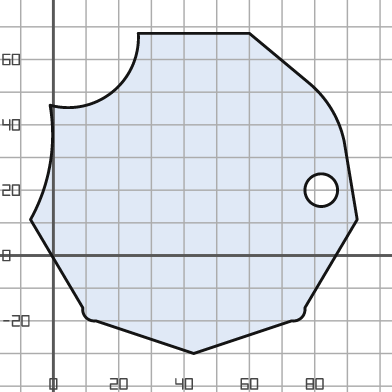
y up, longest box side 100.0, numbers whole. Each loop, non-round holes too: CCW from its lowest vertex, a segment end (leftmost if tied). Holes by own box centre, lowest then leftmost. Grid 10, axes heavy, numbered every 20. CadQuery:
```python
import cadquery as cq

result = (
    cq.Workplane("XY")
    .moveTo(43.0, -30.0)
    .lineTo(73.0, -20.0)
    .threePointArc((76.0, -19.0), (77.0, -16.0))
    .lineTo(93.0, 11.0)
    .lineTo(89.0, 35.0)
    .threePointArc((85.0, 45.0), (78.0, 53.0))
    .lineTo(60.0, 68.0)
    .lineTo(26.0, 68.0)
    .threePointArc((18.0, 50.0), (-1.0, 46.0))
    .threePointArc((-1.0, 28.0), (-7.0, 11.0))
    .lineTo(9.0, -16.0)
    .threePointArc((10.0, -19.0), (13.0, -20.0))
    .close()
    .moveTo(82.0, 20.0)
    .circle(5.0)
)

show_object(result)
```